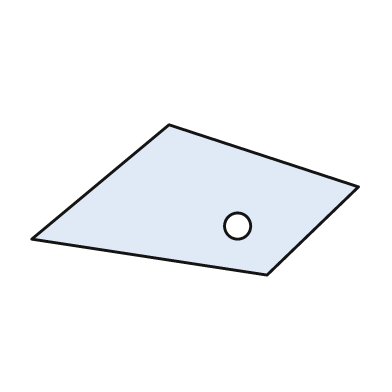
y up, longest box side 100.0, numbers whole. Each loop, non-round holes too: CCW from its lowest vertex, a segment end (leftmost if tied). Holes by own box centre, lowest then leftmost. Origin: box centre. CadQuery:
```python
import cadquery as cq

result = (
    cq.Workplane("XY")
    .moveTo(22.0, -23.0)
    .lineTo(50.0, 4.0)
    .lineTo(-8.0, 23.0)
    .lineTo(-50.0, -12.0)
    .close()
    .moveTo(13.0, -8.0)
    .circle(4.0)
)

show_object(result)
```